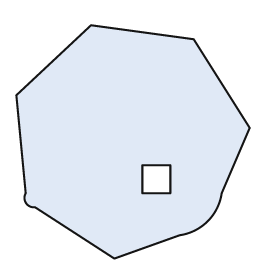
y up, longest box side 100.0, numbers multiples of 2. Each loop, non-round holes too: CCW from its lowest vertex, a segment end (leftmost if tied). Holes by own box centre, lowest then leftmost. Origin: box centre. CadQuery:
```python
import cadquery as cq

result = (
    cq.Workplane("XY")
    .moveTo(-8.0, -50.0)
    .lineTo(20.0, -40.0)
    .threePointArc((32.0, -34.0), (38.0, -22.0))
    .lineTo(50.0, 6.0)
    .lineTo(26.0, 44.0)
    .lineTo(-18.0, 50.0)
    .lineTo(-50.0, 20.0)
    .lineTo(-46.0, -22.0)
    .threePointArc((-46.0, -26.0), (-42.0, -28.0))
    .close()
    .moveTo(4.0, -22.0)
    .lineTo(16.0, -22.0)
    .lineTo(16.0, -10.0)
    .lineTo(4.0, -10.0)
    .close()
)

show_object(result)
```